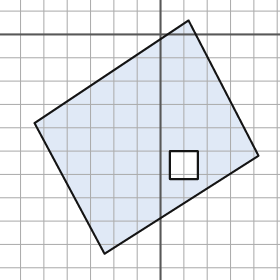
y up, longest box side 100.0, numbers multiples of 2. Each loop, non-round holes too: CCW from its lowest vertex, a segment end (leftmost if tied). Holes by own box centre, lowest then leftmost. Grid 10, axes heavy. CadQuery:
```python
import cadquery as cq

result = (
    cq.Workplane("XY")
    .moveTo(-24.0, -94.0)
    .lineTo(42.0, -52.0)
    .lineTo(12.0, 6.0)
    .lineTo(-54.0, -38.0)
    .close()
    .moveTo(4.0, -62.0)
    .lineTo(16.0, -62.0)
    .lineTo(16.0, -50.0)
    .lineTo(4.0, -50.0)
    .close()
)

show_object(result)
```